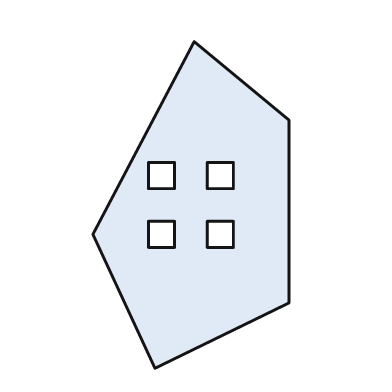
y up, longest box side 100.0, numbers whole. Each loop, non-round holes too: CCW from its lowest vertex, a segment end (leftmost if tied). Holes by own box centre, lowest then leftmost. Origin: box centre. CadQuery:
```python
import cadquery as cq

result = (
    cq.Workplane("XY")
    .moveTo(-11.0, -50.0)
    .lineTo(30.0, -30.0)
    .lineTo(30.0, 26.0)
    .lineTo(1.0, 50.0)
    .lineTo(-30.0, -9.0)
    .close()
    .moveTo(-13.0, -13.0)
    .lineTo(-5.0, -13.0)
    .lineTo(-5.0, -5.0)
    .lineTo(-13.0, -5.0)
    .close()
    .moveTo(5.0, -13.0)
    .lineTo(13.0, -13.0)
    .lineTo(13.0, -5.0)
    .lineTo(5.0, -5.0)
    .close()
    .moveTo(-13.0, 5.0)
    .lineTo(-5.0, 5.0)
    .lineTo(-5.0, 13.0)
    .lineTo(-13.0, 13.0)
    .close()
    .moveTo(5.0, 5.0)
    .lineTo(13.0, 5.0)
    .lineTo(13.0, 13.0)
    .lineTo(5.0, 13.0)
    .close()
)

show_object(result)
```